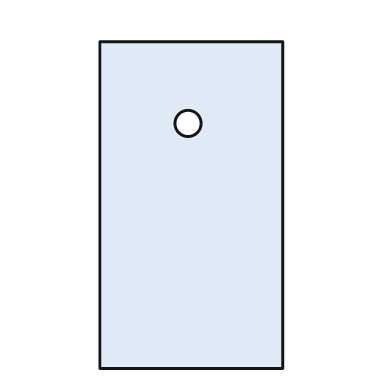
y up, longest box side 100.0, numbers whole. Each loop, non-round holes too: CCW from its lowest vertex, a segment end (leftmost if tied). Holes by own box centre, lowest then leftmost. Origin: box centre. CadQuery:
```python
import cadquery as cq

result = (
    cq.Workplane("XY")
    .moveTo(-28.0, -50.0)
    .lineTo(28.0, -50.0)
    .lineTo(28.0, 50.0)
    .lineTo(-28.0, 50.0)
    .close()
    .moveTo(-1.0, 25.0)
    .circle(4.0)
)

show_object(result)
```